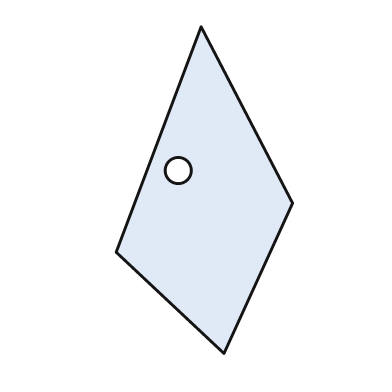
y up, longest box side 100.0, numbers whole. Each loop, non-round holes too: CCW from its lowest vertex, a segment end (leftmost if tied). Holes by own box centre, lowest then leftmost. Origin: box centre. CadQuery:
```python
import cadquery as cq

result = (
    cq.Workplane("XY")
    .moveTo(6.0, -50.0)
    .lineTo(27.0, -4.0)
    .lineTo(-1.0, 50.0)
    .lineTo(-27.0, -19.0)
    .close()
    .moveTo(-8.0, 6.0)
    .circle(4.0)
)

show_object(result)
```